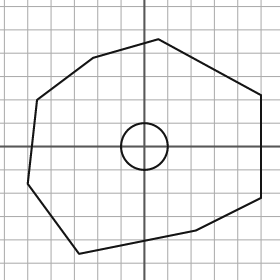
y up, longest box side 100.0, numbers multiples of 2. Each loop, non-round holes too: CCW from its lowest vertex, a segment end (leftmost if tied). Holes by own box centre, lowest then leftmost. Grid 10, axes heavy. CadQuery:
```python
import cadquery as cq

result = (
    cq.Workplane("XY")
    .moveTo(-28.0, -46.0)
    .lineTo(22.0, -36.0)
    .lineTo(50.0, -22.0)
    .lineTo(50.0, 22.0)
    .lineTo(6.0, 46.0)
    .lineTo(-22.0, 38.0)
    .lineTo(-46.0, 20.0)
    .lineTo(-50.0, -16.0)
    .close()
    .moveTo(0.0, 0.0)
    .circle(10.0)
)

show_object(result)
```